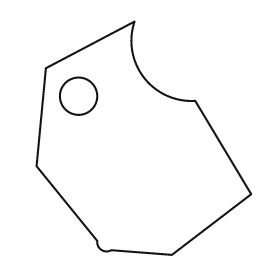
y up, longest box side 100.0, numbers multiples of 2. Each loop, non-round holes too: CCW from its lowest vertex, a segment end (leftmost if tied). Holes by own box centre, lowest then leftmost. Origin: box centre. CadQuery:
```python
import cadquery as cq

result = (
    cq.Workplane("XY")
    .moveTo(12.0, -50.0)
    .lineTo(46.0, -24.0)
    .lineTo(22.0, 16.0)
    .threePointArc((0.0, 26.0), (-4.0, 50.0))
    .lineTo(-42.0, 30.0)
    .lineTo(-46.0, -12.0)
    .lineTo(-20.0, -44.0)
    .threePointArc((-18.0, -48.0), (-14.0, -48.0))
    .close()
    .moveTo(-28.0, 18.0)
    .circle(8.0)
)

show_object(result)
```